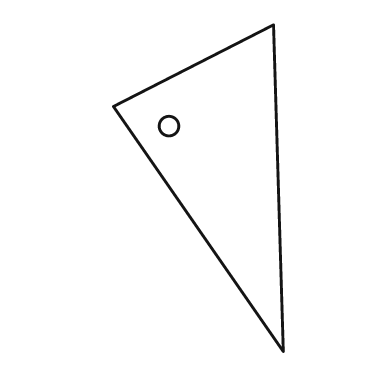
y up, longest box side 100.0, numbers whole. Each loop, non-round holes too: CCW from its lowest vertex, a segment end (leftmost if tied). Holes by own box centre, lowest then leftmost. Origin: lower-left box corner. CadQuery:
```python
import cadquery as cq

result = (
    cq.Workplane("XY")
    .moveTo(52.0, 0.0)
    .lineTo(49.0, 100.0)
    .lineTo(0.0, 75.0)
    .close()
    .moveTo(17.0, 69.0)
    .circle(3.0)
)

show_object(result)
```